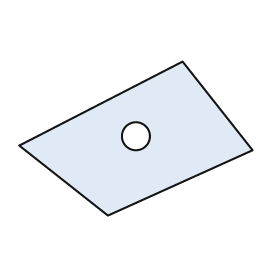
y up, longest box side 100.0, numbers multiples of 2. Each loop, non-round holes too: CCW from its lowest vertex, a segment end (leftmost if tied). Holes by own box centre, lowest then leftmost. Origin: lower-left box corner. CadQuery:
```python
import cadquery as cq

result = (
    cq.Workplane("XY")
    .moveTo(38.0, 0.0)
    .lineTo(100.0, 28.0)
    .lineTo(70.0, 66.0)
    .lineTo(0.0, 30.0)
    .close()
    .moveTo(50.0, 34.0)
    .circle(6.0)
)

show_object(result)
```